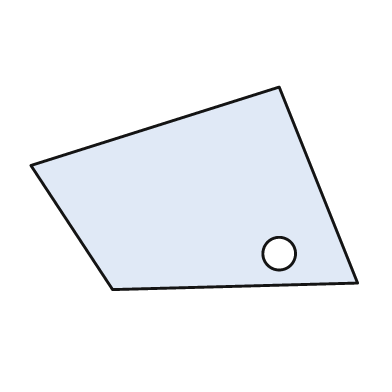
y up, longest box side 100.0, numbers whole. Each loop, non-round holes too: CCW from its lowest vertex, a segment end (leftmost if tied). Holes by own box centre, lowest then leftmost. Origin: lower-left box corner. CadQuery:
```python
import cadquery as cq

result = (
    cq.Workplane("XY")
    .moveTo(25.0, 0.0)
    .lineTo(100.0, 2.0)
    .lineTo(76.0, 62.0)
    .lineTo(0.0, 38.0)
    .close()
    .moveTo(76.0, 11.0)
    .circle(5.0)
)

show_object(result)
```